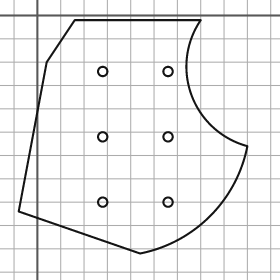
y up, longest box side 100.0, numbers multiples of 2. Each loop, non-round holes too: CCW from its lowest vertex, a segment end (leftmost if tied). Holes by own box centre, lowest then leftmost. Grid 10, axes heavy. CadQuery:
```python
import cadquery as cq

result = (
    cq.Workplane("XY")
    .moveTo(44.0, -102.0)
    .threePointArc((74.0, -86.0), (90.0, -56.0))
    .threePointArc((66.0, -34.0), (70.0, -2.0))
    .lineTo(16.0, -2.0)
    .lineTo(4.0, -20.0)
    .lineTo(-8.0, -84.0)
    .close()
    .moveTo(28.0, -80.0)
    .circle(2.0)
    .moveTo(56.0, -80.0)
    .circle(2.0)
    .moveTo(28.0, -52.0)
    .circle(2.0)
    .moveTo(56.0, -52.0)
    .circle(2.0)
    .moveTo(28.0, -24.0)
    .circle(2.0)
    .moveTo(56.0, -24.0)
    .circle(2.0)
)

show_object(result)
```